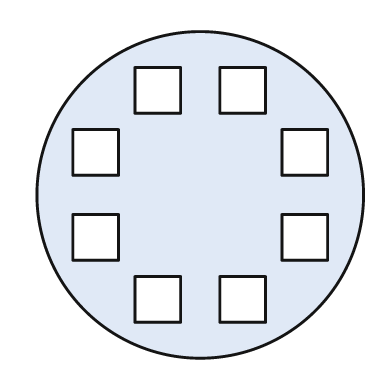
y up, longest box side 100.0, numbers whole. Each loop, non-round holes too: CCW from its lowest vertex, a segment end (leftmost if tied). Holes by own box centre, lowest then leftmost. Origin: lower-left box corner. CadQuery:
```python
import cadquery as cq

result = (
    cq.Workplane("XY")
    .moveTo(50.0, 50.0)
    .circle(50.0)
    .moveTo(30.0, 11.0)
    .lineTo(44.0, 11.0)
    .lineTo(44.0, 25.0)
    .lineTo(30.0, 25.0)
    .close()
    .moveTo(56.0, 11.0)
    .lineTo(70.0, 11.0)
    .lineTo(70.0, 25.0)
    .lineTo(56.0, 25.0)
    .close()
    .moveTo(11.0, 30.0)
    .lineTo(25.0, 30.0)
    .lineTo(25.0, 44.0)
    .lineTo(11.0, 44.0)
    .close()
    .moveTo(75.0, 30.0)
    .lineTo(89.0, 30.0)
    .lineTo(89.0, 44.0)
    .lineTo(75.0, 44.0)
    .close()
    .moveTo(11.0, 56.0)
    .lineTo(25.0, 56.0)
    .lineTo(25.0, 70.0)
    .lineTo(11.0, 70.0)
    .close()
    .moveTo(75.0, 56.0)
    .lineTo(89.0, 56.0)
    .lineTo(89.0, 70.0)
    .lineTo(75.0, 70.0)
    .close()
    .moveTo(30.0, 75.0)
    .lineTo(44.0, 75.0)
    .lineTo(44.0, 89.0)
    .lineTo(30.0, 89.0)
    .close()
    .moveTo(56.0, 75.0)
    .lineTo(70.0, 75.0)
    .lineTo(70.0, 89.0)
    .lineTo(56.0, 89.0)
    .close()
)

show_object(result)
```